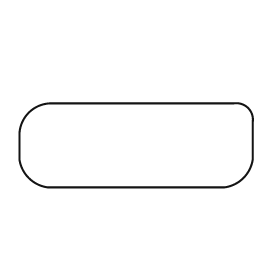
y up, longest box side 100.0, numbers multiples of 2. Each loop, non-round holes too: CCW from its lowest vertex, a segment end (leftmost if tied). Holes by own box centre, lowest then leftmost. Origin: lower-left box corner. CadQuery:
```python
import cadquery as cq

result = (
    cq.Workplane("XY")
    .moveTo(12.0, 0.0)
    .lineTo(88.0, 0.0)
    .threePointArc((96.0, 4.0), (100.0, 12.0))
    .lineTo(100.0, 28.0)
    .threePointArc((98.0, 34.0), (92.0, 36.0))
    .lineTo(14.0, 36.0)
    .threePointArc((4.0, 32.0), (0.0, 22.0))
    .lineTo(0.0, 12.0)
    .threePointArc((4.0, 4.0), (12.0, 0.0))
    .close()
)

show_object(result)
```